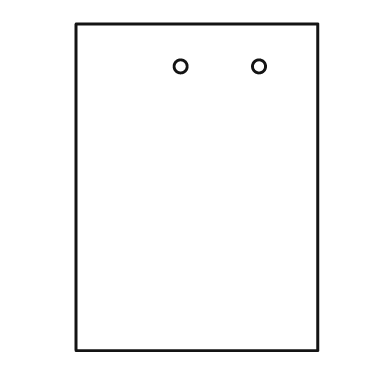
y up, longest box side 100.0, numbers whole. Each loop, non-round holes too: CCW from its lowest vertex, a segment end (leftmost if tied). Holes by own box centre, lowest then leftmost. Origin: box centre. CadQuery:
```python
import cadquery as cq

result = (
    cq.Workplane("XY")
    .moveTo(-37.0, -50.0)
    .lineTo(37.0, -50.0)
    .lineTo(37.0, 50.0)
    .lineTo(-37.0, 50.0)
    .close()
    .moveTo(-5.0, 37.0)
    .circle(2.0)
    .moveTo(19.0, 37.0)
    .circle(2.0)
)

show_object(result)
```